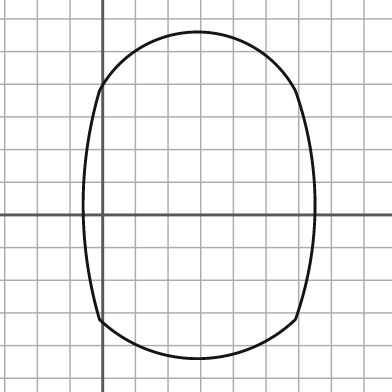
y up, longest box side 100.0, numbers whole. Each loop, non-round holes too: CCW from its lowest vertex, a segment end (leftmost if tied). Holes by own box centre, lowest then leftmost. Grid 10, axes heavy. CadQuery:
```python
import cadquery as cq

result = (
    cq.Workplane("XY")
    .moveTo(-1.0, -32.0)
    .threePointArc((29.0, -44.0), (59.0, -32.0))
    .threePointArc((65.0, 3.0), (59.0, 38.0))
    .threePointArc((29.0, 56.0), (-1.0, 38.0))
    .threePointArc((-6.0, 3.0), (-1.0, -32.0))
    .close()
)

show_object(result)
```